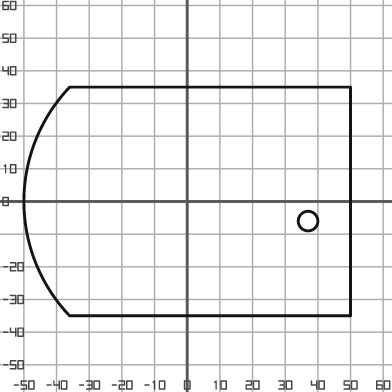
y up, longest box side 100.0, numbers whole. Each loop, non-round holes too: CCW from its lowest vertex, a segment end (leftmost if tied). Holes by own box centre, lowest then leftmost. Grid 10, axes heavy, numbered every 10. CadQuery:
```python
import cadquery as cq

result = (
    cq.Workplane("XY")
    .moveTo(-36.0, -35.0)
    .lineTo(50.0, -35.0)
    .lineTo(50.0, 35.0)
    .lineTo(-36.0, 35.0)
    .threePointArc((-50.0, 0.0), (-36.0, -35.0))
    .close()
    .moveTo(37.0, -6.0)
    .circle(3.0)
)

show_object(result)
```